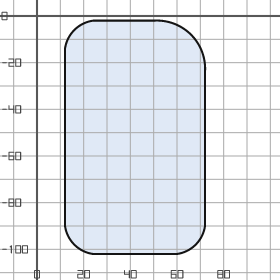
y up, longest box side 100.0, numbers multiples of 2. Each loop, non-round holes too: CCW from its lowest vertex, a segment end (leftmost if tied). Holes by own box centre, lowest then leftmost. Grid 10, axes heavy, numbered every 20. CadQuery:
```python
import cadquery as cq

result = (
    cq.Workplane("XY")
    .moveTo(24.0, -102.0)
    .lineTo(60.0, -102.0)
    .threePointArc((68.0, -98.0), (72.0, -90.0))
    .lineTo(72.0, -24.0)
    .threePointArc((66.0, -8.0), (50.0, -2.0))
    .lineTo(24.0, -2.0)
    .threePointArc((16.0, -6.0), (12.0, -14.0))
    .lineTo(12.0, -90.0)
    .threePointArc((16.0, -98.0), (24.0, -102.0))
    .close()
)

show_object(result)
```